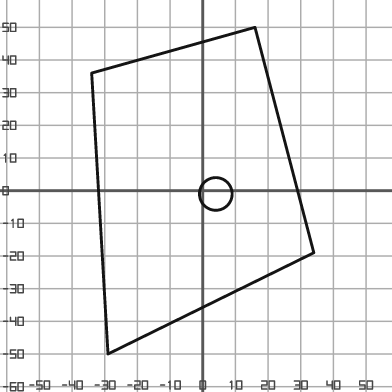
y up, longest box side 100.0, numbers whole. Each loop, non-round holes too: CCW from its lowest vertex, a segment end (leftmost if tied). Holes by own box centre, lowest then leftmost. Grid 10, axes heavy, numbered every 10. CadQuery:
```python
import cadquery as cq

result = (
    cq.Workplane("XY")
    .moveTo(-29.0, -50.0)
    .lineTo(34.0, -19.0)
    .lineTo(16.0, 50.0)
    .lineTo(-34.0, 36.0)
    .close()
    .moveTo(4.0, -1.0)
    .circle(5.0)
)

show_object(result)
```